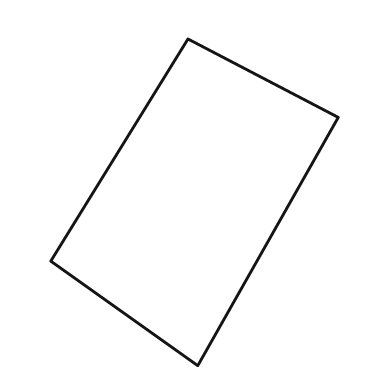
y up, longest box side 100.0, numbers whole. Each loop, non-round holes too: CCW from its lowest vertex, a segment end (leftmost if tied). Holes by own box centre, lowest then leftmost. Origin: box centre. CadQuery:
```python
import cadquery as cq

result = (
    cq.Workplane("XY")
    .moveTo(1.0, -50.0)
    .lineTo(44.0, 26.0)
    .lineTo(-2.0, 50.0)
    .lineTo(-44.0, -18.0)
    .close()
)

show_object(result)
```